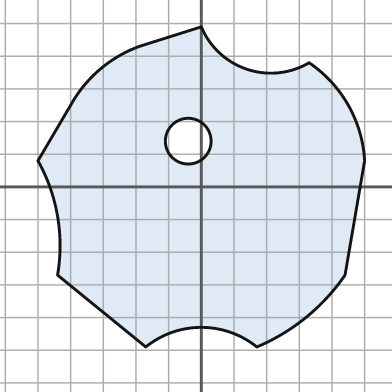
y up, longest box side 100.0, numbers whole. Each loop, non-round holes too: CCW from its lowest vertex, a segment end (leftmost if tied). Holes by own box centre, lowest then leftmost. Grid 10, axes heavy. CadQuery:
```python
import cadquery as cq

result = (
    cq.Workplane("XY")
    .moveTo(-17.0, -49.0)
    .threePointArc((0.0, -43.0), (17.0, -49.0))
    .threePointArc((32.0, -40.0), (44.0, -27.0))
    .lineTo(50.0, 8.0)
    .threePointArc((45.0, 25.0), (33.0, 38.0))
    .threePointArc((14.0, 36.0), (0.0, 49.0))
    .lineTo(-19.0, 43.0)
    .threePointArc((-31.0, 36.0), (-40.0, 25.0))
    .lineTo(-50.0, 8.0)
    .threePointArc((-44.0, -9.0), (-44.0, -27.0))
    .close()
    .moveTo(-4.0, 14.0)
    .circle(7.0)
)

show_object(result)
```